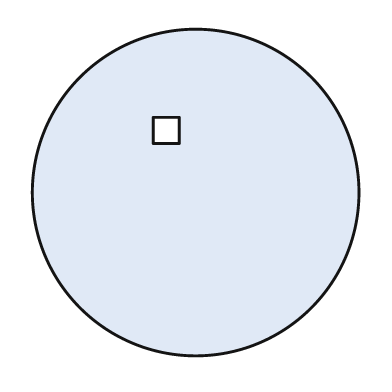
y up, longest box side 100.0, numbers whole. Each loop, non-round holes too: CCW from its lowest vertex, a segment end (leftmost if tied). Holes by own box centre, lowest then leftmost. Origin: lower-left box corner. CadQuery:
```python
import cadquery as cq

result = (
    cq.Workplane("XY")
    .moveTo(50.0, 50.0)
    .circle(50.0)
    .moveTo(37.0, 65.0)
    .lineTo(45.0, 65.0)
    .lineTo(45.0, 73.0)
    .lineTo(37.0, 73.0)
    .close()
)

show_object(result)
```